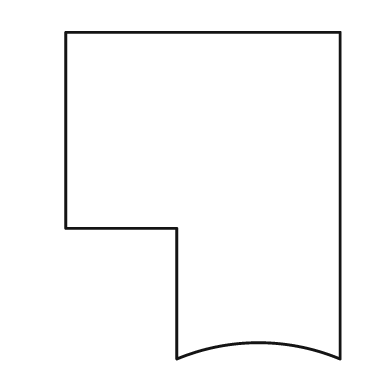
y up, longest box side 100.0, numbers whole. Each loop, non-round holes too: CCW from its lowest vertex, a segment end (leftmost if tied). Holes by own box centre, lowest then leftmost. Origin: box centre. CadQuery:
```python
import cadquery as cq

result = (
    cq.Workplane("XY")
    .moveTo(-8.0, -50.0)
    .threePointArc((17.0, -45.0), (42.0, -50.0))
    .lineTo(42.0, 50.0)
    .lineTo(-42.0, 50.0)
    .lineTo(-42.0, -10.0)
    .lineTo(-8.0, -10.0)
    .close()
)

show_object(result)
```